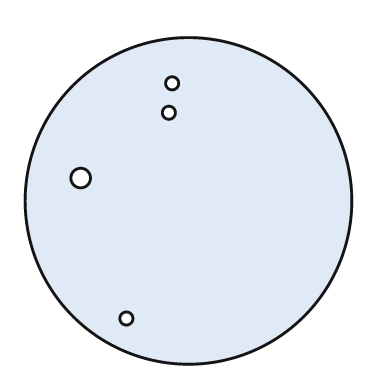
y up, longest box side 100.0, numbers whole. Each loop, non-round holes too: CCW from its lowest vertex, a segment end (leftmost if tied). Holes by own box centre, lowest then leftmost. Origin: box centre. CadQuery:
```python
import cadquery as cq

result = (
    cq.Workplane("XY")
    .moveTo(0.0, 0.0)
    .circle(50.0)
    .moveTo(-19.0, -36.0)
    .circle(2.0)
    .moveTo(-33.0, 7.0)
    .circle(3.0)
    .moveTo(-6.0, 27.0)
    .circle(2.0)
    .moveTo(-5.0, 36.0)
    .circle(2.0)
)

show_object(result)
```